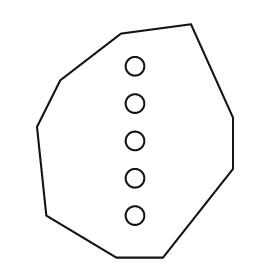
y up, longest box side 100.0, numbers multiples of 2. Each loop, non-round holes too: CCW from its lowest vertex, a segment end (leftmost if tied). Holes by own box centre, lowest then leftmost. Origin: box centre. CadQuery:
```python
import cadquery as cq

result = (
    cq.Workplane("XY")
    .moveTo(-8.0, -50.0)
    .lineTo(12.0, -50.0)
    .lineTo(42.0, -12.0)
    .lineTo(42.0, 10.0)
    .lineTo(24.0, 50.0)
    .lineTo(-6.0, 46.0)
    .lineTo(-32.0, 26.0)
    .lineTo(-42.0, 6.0)
    .lineTo(-38.0, -32.0)
    .close()
    .moveTo(0.0, -32.0)
    .circle(4.0)
    .moveTo(0.0, -16.0)
    .circle(4.0)
    .moveTo(0.0, 0.0)
    .circle(4.0)
    .moveTo(0.0, 16.0)
    .circle(4.0)
    .moveTo(0.0, 32.0)
    .circle(4.0)
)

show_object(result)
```